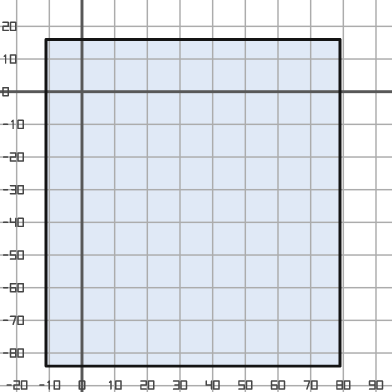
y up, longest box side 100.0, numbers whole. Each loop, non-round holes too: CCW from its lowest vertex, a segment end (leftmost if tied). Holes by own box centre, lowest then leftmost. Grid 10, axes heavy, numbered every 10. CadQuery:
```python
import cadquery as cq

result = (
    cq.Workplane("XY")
    .moveTo(-11.0, -84.0)
    .lineTo(79.0, -84.0)
    .lineTo(79.0, 16.0)
    .lineTo(-11.0, 16.0)
    .close()
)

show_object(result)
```